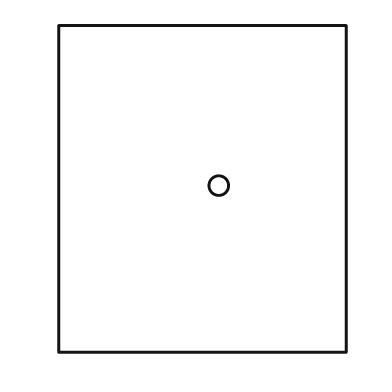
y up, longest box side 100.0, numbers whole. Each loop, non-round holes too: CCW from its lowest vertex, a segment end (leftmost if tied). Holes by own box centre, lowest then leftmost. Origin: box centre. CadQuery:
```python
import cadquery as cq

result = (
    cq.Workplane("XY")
    .moveTo(-44.0, -50.0)
    .lineTo(44.0, -50.0)
    .lineTo(44.0, 50.0)
    .lineTo(-44.0, 50.0)
    .close()
    .moveTo(5.0, 1.0)
    .circle(3.0)
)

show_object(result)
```